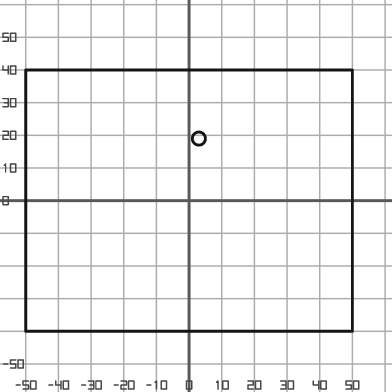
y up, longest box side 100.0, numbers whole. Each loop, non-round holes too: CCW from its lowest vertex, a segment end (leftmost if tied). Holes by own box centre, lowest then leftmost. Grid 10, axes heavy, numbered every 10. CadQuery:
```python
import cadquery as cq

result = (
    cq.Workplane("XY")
    .moveTo(-50.0, -40.0)
    .lineTo(50.0, -40.0)
    .lineTo(50.0, 40.0)
    .lineTo(-50.0, 40.0)
    .close()
    .moveTo(3.0, 19.0)
    .circle(2.0)
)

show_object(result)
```